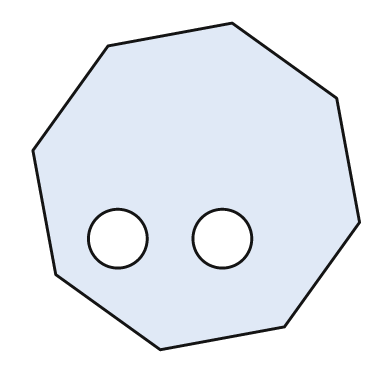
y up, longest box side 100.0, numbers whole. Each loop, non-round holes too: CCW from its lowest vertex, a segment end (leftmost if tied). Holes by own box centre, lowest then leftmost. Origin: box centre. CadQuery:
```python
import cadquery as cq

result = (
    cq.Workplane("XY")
    .moveTo(-11.0, -50.0)
    .lineTo(27.0, -43.0)
    .lineTo(50.0, -11.0)
    .lineTo(43.0, 27.0)
    .lineTo(11.0, 50.0)
    .lineTo(-27.0, 43.0)
    .lineTo(-50.0, 11.0)
    .lineTo(-43.0, -27.0)
    .close()
    .moveTo(-24.0, -16.0)
    .circle(9.0)
    .moveTo(8.0, -16.0)
    .circle(9.0)
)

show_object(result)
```